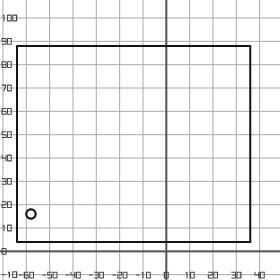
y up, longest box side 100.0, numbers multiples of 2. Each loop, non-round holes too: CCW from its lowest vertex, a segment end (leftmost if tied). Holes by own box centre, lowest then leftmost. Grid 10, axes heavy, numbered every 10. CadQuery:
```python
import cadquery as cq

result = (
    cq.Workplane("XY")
    .moveTo(-64.0, 4.0)
    .lineTo(36.0, 4.0)
    .lineTo(36.0, 88.0)
    .lineTo(-64.0, 88.0)
    .close()
    .moveTo(-58.0, 16.0)
    .circle(2.0)
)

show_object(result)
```